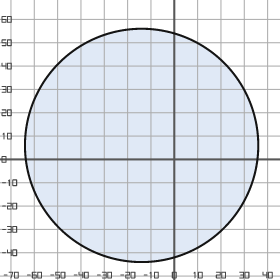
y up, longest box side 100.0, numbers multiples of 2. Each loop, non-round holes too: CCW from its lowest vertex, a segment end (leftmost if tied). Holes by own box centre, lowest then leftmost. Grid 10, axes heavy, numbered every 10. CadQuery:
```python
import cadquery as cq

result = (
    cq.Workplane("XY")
    .moveTo(-14.0, 6.0)
    .circle(50.0)
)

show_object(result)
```